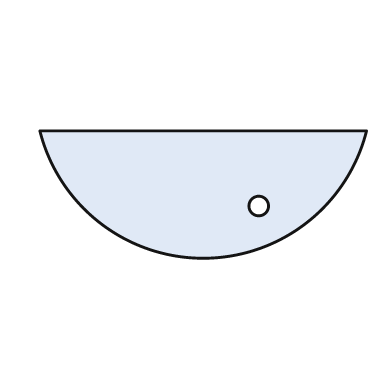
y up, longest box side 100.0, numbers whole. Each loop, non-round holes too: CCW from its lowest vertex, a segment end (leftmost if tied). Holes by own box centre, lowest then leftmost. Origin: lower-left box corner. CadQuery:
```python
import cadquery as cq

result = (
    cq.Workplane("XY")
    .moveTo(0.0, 39.0)
    .threePointArc((50.0, 0.0), (100.0, 39.0))
    .close()
    .moveTo(67.0, 16.0)
    .circle(3.0)
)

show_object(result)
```